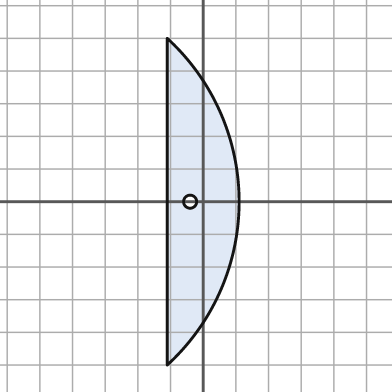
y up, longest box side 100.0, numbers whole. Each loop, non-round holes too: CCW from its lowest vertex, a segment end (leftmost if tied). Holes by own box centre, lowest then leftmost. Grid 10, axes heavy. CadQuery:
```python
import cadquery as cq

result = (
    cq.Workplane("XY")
    .moveTo(-11.0, -50.0)
    .threePointArc((11.0, 0.0), (-11.0, 50.0))
    .close()
    .moveTo(-4.0, 0.0)
    .circle(2.0)
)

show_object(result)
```